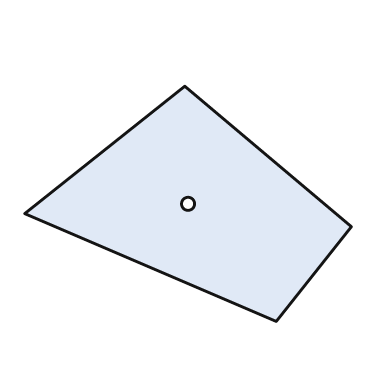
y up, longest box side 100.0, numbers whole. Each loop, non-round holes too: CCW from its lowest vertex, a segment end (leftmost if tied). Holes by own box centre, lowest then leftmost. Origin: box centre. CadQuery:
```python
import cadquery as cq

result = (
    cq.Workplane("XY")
    .moveTo(27.0, -36.0)
    .lineTo(50.0, -7.0)
    .lineTo(-1.0, 36.0)
    .lineTo(-50.0, -3.0)
    .close()
    .moveTo(0.0, 0.0)
    .circle(2.0)
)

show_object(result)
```